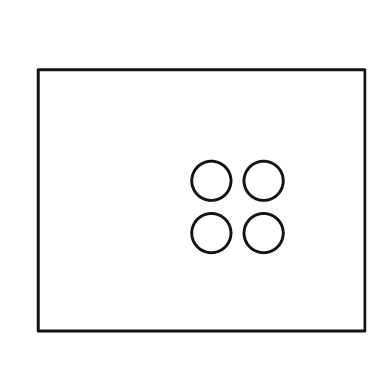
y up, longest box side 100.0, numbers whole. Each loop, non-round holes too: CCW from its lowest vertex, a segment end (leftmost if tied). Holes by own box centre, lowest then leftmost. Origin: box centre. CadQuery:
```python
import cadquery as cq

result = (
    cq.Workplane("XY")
    .moveTo(-50.0, -40.0)
    .lineTo(50.0, -40.0)
    .lineTo(50.0, 40.0)
    .lineTo(-50.0, 40.0)
    .close()
    .moveTo(3.0, -10.0)
    .circle(6.0)
    .moveTo(19.0, -10.0)
    .circle(6.0)
    .moveTo(3.0, 6.0)
    .circle(6.0)
    .moveTo(19.0, 6.0)
    .circle(6.0)
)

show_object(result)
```